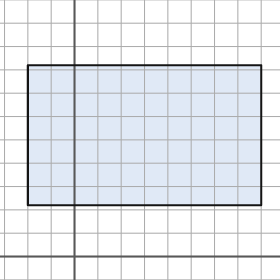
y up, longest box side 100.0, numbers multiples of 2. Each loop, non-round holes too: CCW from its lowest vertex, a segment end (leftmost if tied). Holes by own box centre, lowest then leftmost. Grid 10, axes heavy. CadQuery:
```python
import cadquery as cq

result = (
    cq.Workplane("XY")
    .moveTo(-20.0, 22.0)
    .lineTo(80.0, 22.0)
    .lineTo(80.0, 82.0)
    .lineTo(-20.0, 82.0)
    .close()
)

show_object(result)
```